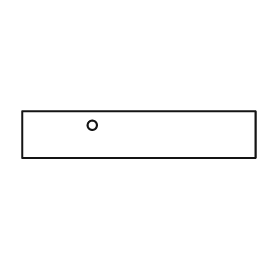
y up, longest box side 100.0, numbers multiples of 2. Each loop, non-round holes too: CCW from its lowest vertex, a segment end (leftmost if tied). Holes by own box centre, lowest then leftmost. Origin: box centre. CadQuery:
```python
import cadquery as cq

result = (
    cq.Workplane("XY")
    .moveTo(-50.0, -10.0)
    .lineTo(50.0, -10.0)
    .lineTo(50.0, 10.0)
    .lineTo(-50.0, 10.0)
    .close()
    .moveTo(-20.0, 4.0)
    .circle(2.0)
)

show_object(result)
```